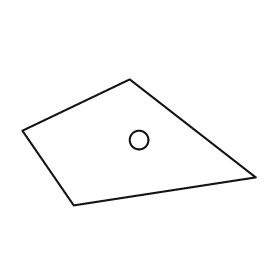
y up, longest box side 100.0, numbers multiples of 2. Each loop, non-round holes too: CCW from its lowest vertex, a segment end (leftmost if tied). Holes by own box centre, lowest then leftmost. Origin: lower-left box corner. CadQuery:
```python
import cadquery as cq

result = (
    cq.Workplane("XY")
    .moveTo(22.0, 0.0)
    .lineTo(100.0, 12.0)
    .lineTo(46.0, 54.0)
    .lineTo(0.0, 32.0)
    .close()
    .moveTo(50.0, 28.0)
    .circle(4.0)
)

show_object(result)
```